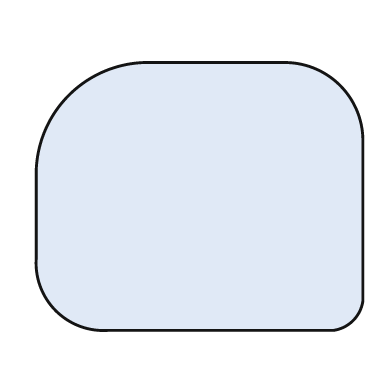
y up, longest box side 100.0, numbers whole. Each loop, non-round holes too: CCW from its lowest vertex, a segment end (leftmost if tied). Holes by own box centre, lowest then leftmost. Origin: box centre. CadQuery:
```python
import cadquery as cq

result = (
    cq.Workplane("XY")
    .moveTo(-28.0, -41.0)
    .lineTo(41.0, -41.0)
    .threePointArc((47.0, -38.0), (50.0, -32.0))
    .lineTo(50.0, 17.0)
    .threePointArc((43.0, 34.0), (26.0, 41.0))
    .lineTo(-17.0, 41.0)
    .threePointArc((-40.0, 31.0), (-50.0, 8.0))
    .lineTo(-50.0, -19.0)
    .threePointArc((-44.0, -35.0), (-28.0, -41.0))
    .close()
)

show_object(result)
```